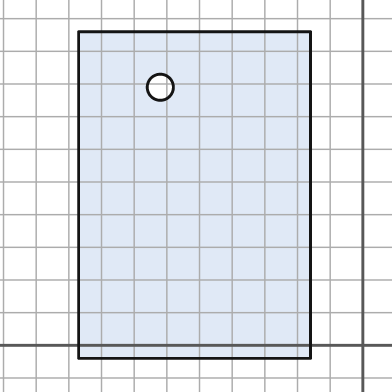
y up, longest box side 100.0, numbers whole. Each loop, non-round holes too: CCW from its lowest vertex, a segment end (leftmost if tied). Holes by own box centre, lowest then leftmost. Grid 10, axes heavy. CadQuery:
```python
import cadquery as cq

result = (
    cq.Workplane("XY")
    .moveTo(-87.0, -4.0)
    .lineTo(-16.0, -4.0)
    .lineTo(-16.0, 96.0)
    .lineTo(-87.0, 96.0)
    .close()
    .moveTo(-62.0, 79.0)
    .circle(4.0)
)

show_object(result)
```